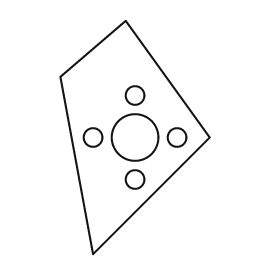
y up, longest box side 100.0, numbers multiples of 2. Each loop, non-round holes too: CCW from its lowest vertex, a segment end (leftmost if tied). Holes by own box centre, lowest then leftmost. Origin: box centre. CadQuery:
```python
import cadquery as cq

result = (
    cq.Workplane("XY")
    .moveTo(-18.0, -50.0)
    .lineTo(32.0, 0.0)
    .lineTo(-4.0, 50.0)
    .lineTo(-32.0, 26.0)
    .close()
    .moveTo(0.0, -18.0)
    .circle(4.0)
    .moveTo(-18.0, 0.0)
    .circle(4.0)
    .moveTo(0.0, 0.0)
    .circle(10.0)
    .moveTo(18.0, 0.0)
    .circle(4.0)
    .moveTo(0.0, 18.0)
    .circle(4.0)
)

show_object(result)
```